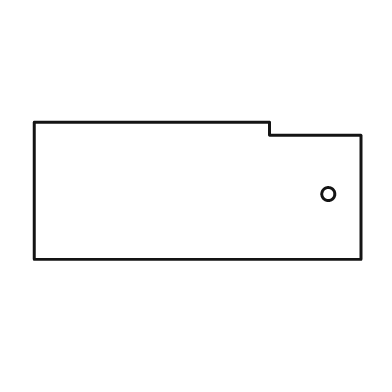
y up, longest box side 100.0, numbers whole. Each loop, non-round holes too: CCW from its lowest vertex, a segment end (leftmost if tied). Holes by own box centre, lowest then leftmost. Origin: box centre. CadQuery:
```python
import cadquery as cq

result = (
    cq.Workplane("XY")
    .moveTo(-50.0, -21.0)
    .lineTo(50.0, -21.0)
    .lineTo(50.0, 17.0)
    .lineTo(22.0, 17.0)
    .lineTo(22.0, 21.0)
    .lineTo(-50.0, 21.0)
    .close()
    .moveTo(40.0, -1.0)
    .circle(2.0)
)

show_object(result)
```